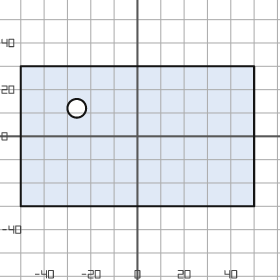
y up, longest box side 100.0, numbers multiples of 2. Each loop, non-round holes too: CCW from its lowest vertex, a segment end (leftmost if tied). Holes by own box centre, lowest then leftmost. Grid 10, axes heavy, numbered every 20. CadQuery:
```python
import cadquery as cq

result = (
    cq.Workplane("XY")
    .moveTo(-50.0, -30.0)
    .lineTo(50.0, -30.0)
    .lineTo(50.0, 30.0)
    .lineTo(-50.0, 30.0)
    .close()
    .moveTo(-26.0, 12.0)
    .circle(4.0)
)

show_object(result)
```